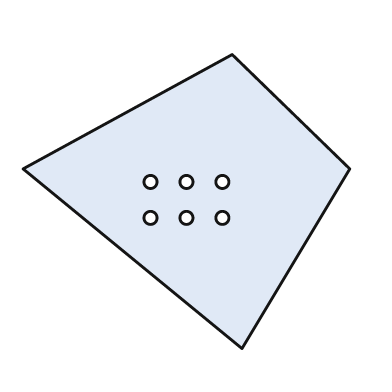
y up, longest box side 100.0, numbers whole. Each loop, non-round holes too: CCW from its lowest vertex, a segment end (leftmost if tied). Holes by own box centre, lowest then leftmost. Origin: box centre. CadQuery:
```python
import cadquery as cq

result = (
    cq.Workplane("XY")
    .moveTo(17.0, -45.0)
    .lineTo(50.0, 10.0)
    .lineTo(14.0, 45.0)
    .lineTo(-50.0, 10.0)
    .close()
    .moveTo(-11.0, -5.0)
    .circle(2.0)
    .moveTo(0.0, -5.0)
    .circle(2.0)
    .moveTo(11.0, -5.0)
    .circle(2.0)
    .moveTo(-11.0, 6.0)
    .circle(2.0)
    .moveTo(0.0, 6.0)
    .circle(2.0)
    .moveTo(11.0, 6.0)
    .circle(2.0)
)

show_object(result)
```